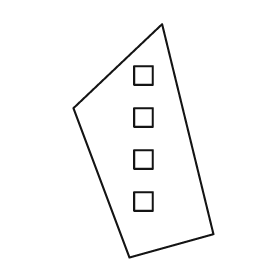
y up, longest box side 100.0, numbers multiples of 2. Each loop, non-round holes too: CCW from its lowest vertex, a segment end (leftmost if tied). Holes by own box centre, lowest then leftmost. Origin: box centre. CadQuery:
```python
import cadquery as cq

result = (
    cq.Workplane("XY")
    .moveTo(-6.0, -50.0)
    .lineTo(30.0, -40.0)
    .lineTo(8.0, 50.0)
    .lineTo(-30.0, 14.0)
    .close()
    .moveTo(-4.0, -30.0)
    .lineTo(4.0, -30.0)
    .lineTo(4.0, -22.0)
    .lineTo(-4.0, -22.0)
    .close()
    .moveTo(-4.0, -12.0)
    .lineTo(4.0, -12.0)
    .lineTo(4.0, -4.0)
    .lineTo(-4.0, -4.0)
    .close()
    .moveTo(-4.0, 6.0)
    .lineTo(4.0, 6.0)
    .lineTo(4.0, 14.0)
    .lineTo(-4.0, 14.0)
    .close()
    .moveTo(-4.0, 24.0)
    .lineTo(4.0, 24.0)
    .lineTo(4.0, 32.0)
    .lineTo(-4.0, 32.0)
    .close()
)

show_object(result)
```